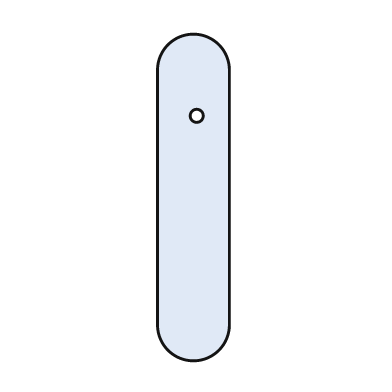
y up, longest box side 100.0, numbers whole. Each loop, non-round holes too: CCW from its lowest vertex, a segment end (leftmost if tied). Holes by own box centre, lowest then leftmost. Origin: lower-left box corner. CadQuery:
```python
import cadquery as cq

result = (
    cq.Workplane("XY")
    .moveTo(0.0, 11.0)
    .threePointArc((11.0, 0.0), (22.0, 11.0))
    .lineTo(22.0, 89.0)
    .threePointArc((11.0, 100.0), (0.0, 89.0))
    .close()
    .moveTo(12.0, 75.0)
    .circle(2.0)
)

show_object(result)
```